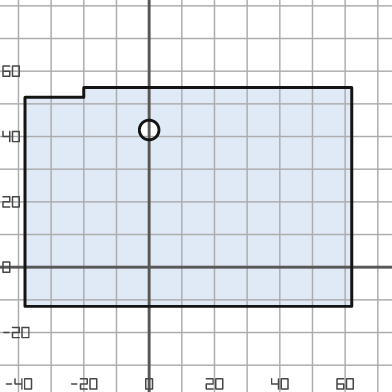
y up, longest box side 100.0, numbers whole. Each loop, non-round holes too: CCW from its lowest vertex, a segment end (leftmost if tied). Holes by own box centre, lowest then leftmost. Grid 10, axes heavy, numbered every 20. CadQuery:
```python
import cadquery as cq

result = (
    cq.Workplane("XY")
    .moveTo(-38.0, -12.0)
    .lineTo(62.0, -12.0)
    .lineTo(62.0, 55.0)
    .lineTo(-20.0, 55.0)
    .lineTo(-20.0, 52.0)
    .lineTo(-38.0, 52.0)
    .close()
    .moveTo(0.0, 42.0)
    .circle(3.0)
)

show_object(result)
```